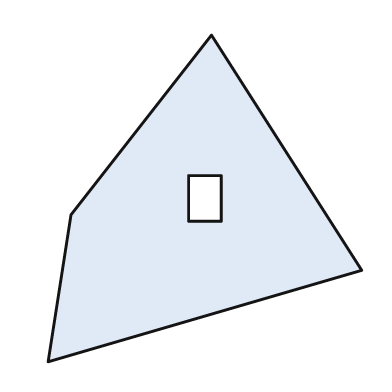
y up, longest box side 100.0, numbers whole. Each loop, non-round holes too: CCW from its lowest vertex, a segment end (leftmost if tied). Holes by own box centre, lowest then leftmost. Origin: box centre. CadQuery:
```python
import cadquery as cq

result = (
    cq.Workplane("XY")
    .moveTo(-48.0, -50.0)
    .lineTo(48.0, -22.0)
    .lineTo(2.0, 50.0)
    .lineTo(-41.0, -5.0)
    .close()
    .moveTo(-5.0, -7.0)
    .lineTo(5.0, -7.0)
    .lineTo(5.0, 7.0)
    .lineTo(-5.0, 7.0)
    .close()
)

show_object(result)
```